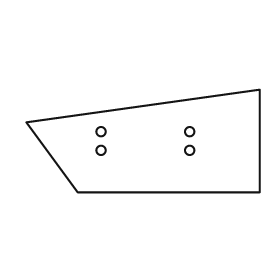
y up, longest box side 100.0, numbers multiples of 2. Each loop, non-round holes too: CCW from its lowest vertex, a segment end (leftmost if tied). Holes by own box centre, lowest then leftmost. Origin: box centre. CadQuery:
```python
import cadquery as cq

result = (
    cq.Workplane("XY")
    .moveTo(-28.0, -22.0)
    .lineTo(50.0, -22.0)
    .lineTo(50.0, 22.0)
    .lineTo(-50.0, 8.0)
    .close()
    .moveTo(-18.0, -4.0)
    .circle(2.0)
    .moveTo(20.0, -4.0)
    .circle(2.0)
    .moveTo(-18.0, 4.0)
    .circle(2.0)
    .moveTo(20.0, 4.0)
    .circle(2.0)
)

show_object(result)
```